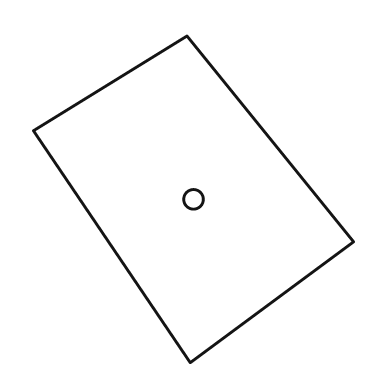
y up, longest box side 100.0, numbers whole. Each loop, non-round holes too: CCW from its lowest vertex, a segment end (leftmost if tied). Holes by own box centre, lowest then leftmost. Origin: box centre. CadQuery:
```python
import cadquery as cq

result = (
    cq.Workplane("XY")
    .moveTo(-1.0, -50.0)
    .lineTo(49.0, -13.0)
    .lineTo(-2.0, 50.0)
    .lineTo(-49.0, 21.0)
    .close()
    .moveTo(0.0, 0.0)
    .circle(3.0)
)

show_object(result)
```